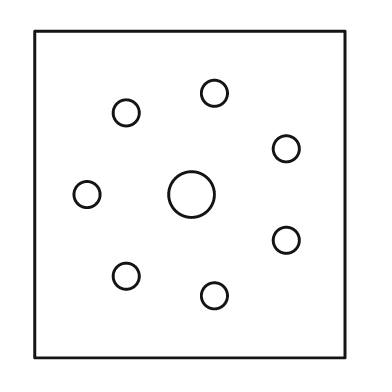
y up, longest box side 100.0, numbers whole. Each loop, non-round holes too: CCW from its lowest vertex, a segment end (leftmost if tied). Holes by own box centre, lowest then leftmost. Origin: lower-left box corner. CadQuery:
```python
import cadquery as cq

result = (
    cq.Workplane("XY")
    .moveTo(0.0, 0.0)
    .lineTo(95.0, 0.0)
    .lineTo(95.0, 100.0)
    .lineTo(0.0, 100.0)
    .close()
    .moveTo(55.0, 19.0)
    .circle(4.0)
    .moveTo(28.0, 25.0)
    .circle(4.0)
    .moveTo(77.0, 36.0)
    .circle(4.0)
    .moveTo(16.0, 50.0)
    .circle(4.0)
    .moveTo(48.0, 50.0)
    .circle(7.0)
    .moveTo(77.0, 64.0)
    .circle(4.0)
    .moveTo(28.0, 75.0)
    .circle(4.0)
    .moveTo(55.0, 81.0)
    .circle(4.0)
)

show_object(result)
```